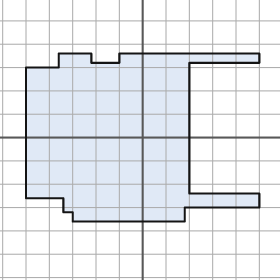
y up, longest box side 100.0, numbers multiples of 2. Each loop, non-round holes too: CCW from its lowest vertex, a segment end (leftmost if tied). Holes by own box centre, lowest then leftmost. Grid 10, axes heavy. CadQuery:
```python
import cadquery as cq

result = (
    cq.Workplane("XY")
    .moveTo(-30.0, -36.0)
    .lineTo(18.0, -36.0)
    .lineTo(18.0, -30.0)
    .lineTo(50.0, -30.0)
    .lineTo(50.0, -24.0)
    .lineTo(20.0, -24.0)
    .lineTo(20.0, 32.0)
    .lineTo(50.0, 32.0)
    .lineTo(50.0, 36.0)
    .lineTo(-10.0, 36.0)
    .lineTo(-10.0, 32.0)
    .lineTo(-22.0, 32.0)
    .lineTo(-22.0, 36.0)
    .lineTo(-36.0, 36.0)
    .lineTo(-36.0, 30.0)
    .lineTo(-50.0, 30.0)
    .lineTo(-50.0, -26.0)
    .lineTo(-34.0, -26.0)
    .lineTo(-34.0, -32.0)
    .lineTo(-30.0, -32.0)
    .close()
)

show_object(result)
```